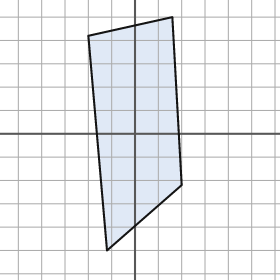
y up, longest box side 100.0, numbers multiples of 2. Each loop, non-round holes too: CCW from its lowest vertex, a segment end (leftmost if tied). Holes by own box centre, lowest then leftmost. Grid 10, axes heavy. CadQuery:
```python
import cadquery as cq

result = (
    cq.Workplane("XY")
    .moveTo(-12.0, -50.0)
    .lineTo(20.0, -22.0)
    .lineTo(16.0, 50.0)
    .lineTo(-20.0, 42.0)
    .close()
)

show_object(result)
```